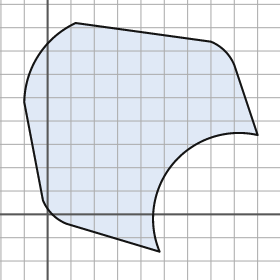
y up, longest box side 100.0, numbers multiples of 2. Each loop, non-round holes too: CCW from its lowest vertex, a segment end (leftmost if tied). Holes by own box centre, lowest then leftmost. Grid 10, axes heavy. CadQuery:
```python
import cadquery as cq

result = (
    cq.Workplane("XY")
    .moveTo(48.0, -16.0)
    .threePointArc((54.0, 22.0), (90.0, 34.0))
    .lineTo(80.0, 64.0)
    .threePointArc((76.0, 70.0), (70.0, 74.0))
    .lineTo(12.0, 82.0)
    .threePointArc((-4.0, 68.0), (-10.0, 48.0))
    .lineTo(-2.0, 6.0)
    .threePointArc((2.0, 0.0), (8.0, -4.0))
    .close()
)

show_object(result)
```